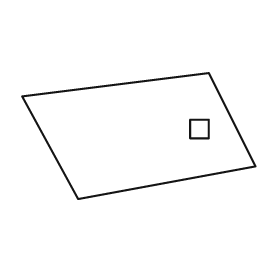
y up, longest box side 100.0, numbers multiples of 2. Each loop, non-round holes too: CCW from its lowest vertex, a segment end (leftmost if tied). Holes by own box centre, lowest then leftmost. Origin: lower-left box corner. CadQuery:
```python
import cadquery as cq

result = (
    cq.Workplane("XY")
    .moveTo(24.0, 0.0)
    .lineTo(100.0, 14.0)
    .lineTo(80.0, 54.0)
    .lineTo(0.0, 44.0)
    .close()
    .moveTo(72.0, 26.0)
    .lineTo(80.0, 26.0)
    .lineTo(80.0, 34.0)
    .lineTo(72.0, 34.0)
    .close()
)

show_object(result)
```